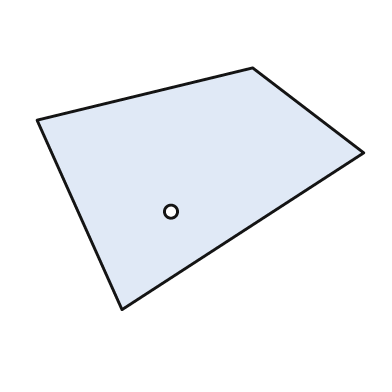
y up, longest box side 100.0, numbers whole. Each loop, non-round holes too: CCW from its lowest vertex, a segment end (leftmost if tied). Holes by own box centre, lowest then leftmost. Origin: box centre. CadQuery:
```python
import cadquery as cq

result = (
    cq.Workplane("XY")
    .moveTo(-24.0, -37.0)
    .lineTo(50.0, 11.0)
    .lineTo(16.0, 37.0)
    .lineTo(-50.0, 21.0)
    .close()
    .moveTo(-9.0, -7.0)
    .circle(2.0)
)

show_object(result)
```